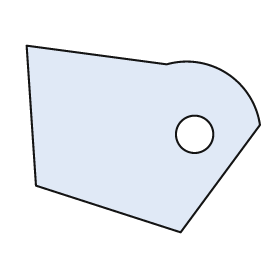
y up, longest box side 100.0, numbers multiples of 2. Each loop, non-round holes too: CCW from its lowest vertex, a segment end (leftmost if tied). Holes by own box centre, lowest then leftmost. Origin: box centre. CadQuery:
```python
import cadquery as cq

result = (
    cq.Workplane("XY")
    .moveTo(16.0, -40.0)
    .lineTo(50.0, 6.0)
    .threePointArc((36.0, 28.0), (10.0, 32.0))
    .lineTo(-50.0, 40.0)
    .lineTo(-46.0, -20.0)
    .close()
    .moveTo(22.0, 2.0)
    .circle(8.0)
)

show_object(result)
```